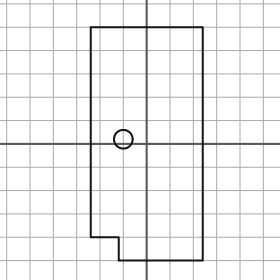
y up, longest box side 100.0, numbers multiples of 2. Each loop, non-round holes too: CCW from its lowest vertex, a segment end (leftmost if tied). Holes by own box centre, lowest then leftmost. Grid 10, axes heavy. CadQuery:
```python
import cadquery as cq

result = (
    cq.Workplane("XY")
    .moveTo(-12.0, -50.0)
    .lineTo(24.0, -50.0)
    .lineTo(24.0, 50.0)
    .lineTo(-24.0, 50.0)
    .lineTo(-24.0, -40.0)
    .lineTo(-12.0, -40.0)
    .close()
    .moveTo(-10.0, 2.0)
    .circle(4.0)
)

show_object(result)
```